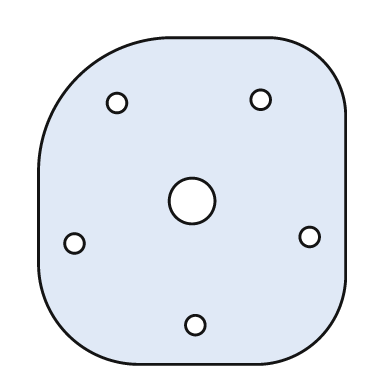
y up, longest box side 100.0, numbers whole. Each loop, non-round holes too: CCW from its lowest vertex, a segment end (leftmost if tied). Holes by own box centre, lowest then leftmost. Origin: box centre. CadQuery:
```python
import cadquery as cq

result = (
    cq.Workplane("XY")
    .moveTo(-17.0, -50.0)
    .lineTo(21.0, -50.0)
    .threePointArc((39.0, -42.0), (47.0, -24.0))
    .lineTo(47.0, 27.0)
    .threePointArc((40.0, 43.0), (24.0, 50.0))
    .lineTo(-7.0, 50.0)
    .threePointArc((-35.0, 38.0), (-47.0, 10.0))
    .lineTo(-47.0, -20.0)
    .threePointArc((-38.0, -41.0), (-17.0, -50.0))
    .close()
    .moveTo(1.0, -38.0)
    .circle(3.0)
    .moveTo(-36.0, -13.0)
    .circle(3.0)
    .moveTo(36.0, -11.0)
    .circle(3.0)
    .moveTo(0.0, 0.0)
    .circle(7.0)
    .moveTo(-23.0, 30.0)
    .circle(3.0)
    .moveTo(21.0, 31.0)
    .circle(3.0)
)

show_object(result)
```